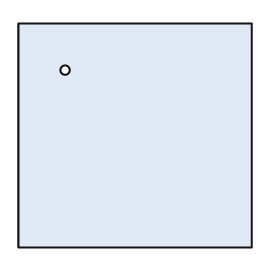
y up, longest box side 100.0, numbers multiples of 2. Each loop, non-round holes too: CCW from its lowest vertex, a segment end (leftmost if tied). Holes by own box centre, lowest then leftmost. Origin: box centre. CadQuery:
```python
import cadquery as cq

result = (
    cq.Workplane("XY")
    .moveTo(-50.0, -48.0)
    .lineTo(50.0, -48.0)
    .lineTo(50.0, 48.0)
    .lineTo(-50.0, 48.0)
    .close()
    .moveTo(-30.0, 28.0)
    .circle(2.0)
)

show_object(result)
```